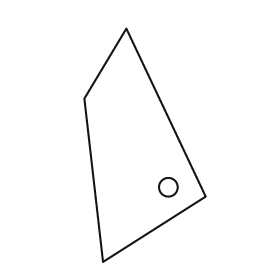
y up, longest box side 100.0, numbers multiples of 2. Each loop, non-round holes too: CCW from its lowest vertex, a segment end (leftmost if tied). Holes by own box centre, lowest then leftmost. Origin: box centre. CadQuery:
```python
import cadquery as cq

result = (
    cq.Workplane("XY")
    .moveTo(-18.0, -50.0)
    .lineTo(26.0, -22.0)
    .lineTo(-8.0, 50.0)
    .lineTo(-26.0, 20.0)
    .close()
    .moveTo(10.0, -18.0)
    .circle(4.0)
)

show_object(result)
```